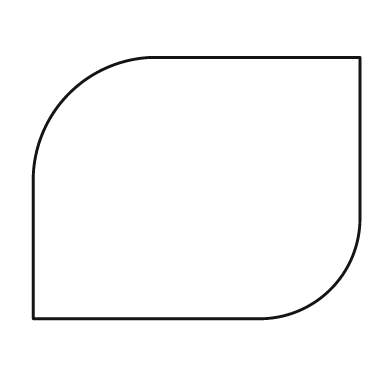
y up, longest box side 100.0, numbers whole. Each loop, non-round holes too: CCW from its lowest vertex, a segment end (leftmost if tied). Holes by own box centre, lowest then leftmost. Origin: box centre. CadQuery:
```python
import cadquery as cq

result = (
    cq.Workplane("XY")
    .moveTo(-50.0, -40.0)
    .lineTo(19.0, -40.0)
    .threePointArc((41.0, -31.0), (50.0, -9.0))
    .lineTo(50.0, 40.0)
    .lineTo(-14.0, 40.0)
    .threePointArc((-39.0, 29.0), (-50.0, 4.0))
    .close()
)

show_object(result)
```